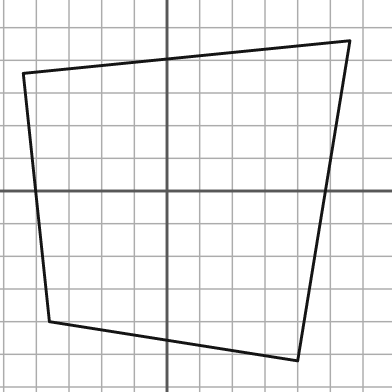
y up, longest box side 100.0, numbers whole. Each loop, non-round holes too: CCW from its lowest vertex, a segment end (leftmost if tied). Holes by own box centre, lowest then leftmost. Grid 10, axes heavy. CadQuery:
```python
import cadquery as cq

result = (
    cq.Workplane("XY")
    .moveTo(40.0, -52.0)
    .lineTo(56.0, 46.0)
    .lineTo(-44.0, 36.0)
    .lineTo(-36.0, -40.0)
    .close()
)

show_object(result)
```